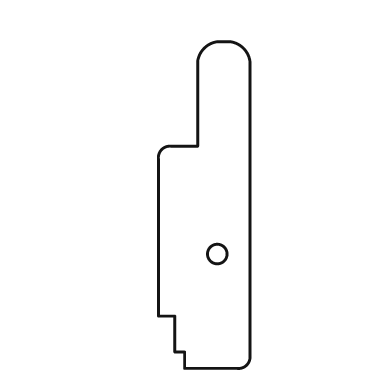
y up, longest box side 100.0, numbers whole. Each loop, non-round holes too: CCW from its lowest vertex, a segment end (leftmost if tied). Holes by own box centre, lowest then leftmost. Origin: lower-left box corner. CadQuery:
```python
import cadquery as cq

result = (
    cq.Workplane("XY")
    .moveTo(8.0, 0.0)
    .lineTo(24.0, 0.0)
    .threePointArc((27.0, 1.0), (28.0, 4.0))
    .lineTo(28.0, 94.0)
    .threePointArc((26.0, 98.0), (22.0, 100.0))
    .lineTo(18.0, 100.0)
    .threePointArc((14.0, 98.0), (12.0, 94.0))
    .lineTo(12.0, 68.0)
    .lineTo(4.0, 68.0)
    .threePointArc((1.0, 67.0), (0.0, 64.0))
    .lineTo(0.0, 16.0)
    .lineTo(5.0, 16.0)
    .lineTo(5.0, 5.0)
    .lineTo(8.0, 5.0)
    .close()
    .moveTo(18.0, 35.0)
    .circle(3.0)
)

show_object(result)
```